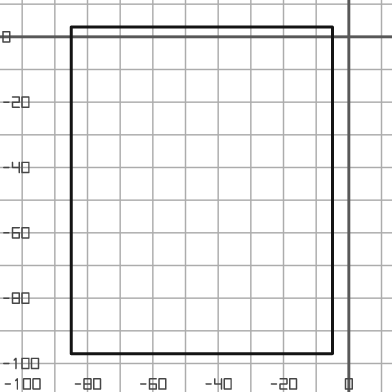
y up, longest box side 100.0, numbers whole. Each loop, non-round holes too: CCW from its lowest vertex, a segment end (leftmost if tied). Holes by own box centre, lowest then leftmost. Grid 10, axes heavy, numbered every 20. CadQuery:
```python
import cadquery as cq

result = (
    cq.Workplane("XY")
    .moveTo(-85.0, -97.0)
    .lineTo(-5.0, -97.0)
    .lineTo(-5.0, 3.0)
    .lineTo(-85.0, 3.0)
    .close()
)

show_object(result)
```